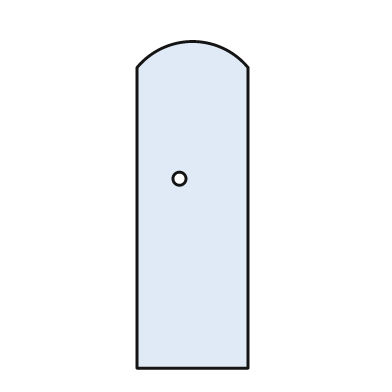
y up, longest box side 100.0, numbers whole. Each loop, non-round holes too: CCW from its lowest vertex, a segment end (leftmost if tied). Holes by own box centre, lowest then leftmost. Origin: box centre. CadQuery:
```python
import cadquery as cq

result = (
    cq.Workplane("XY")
    .moveTo(-17.0, -50.0)
    .lineTo(17.0, -50.0)
    .lineTo(17.0, 42.0)
    .threePointArc((0.0, 50.0), (-17.0, 42.0))
    .close()
    .moveTo(-4.0, 8.0)
    .circle(2.0)
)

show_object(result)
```